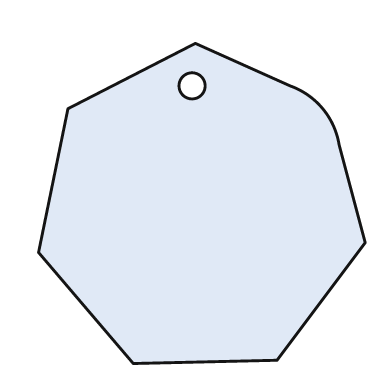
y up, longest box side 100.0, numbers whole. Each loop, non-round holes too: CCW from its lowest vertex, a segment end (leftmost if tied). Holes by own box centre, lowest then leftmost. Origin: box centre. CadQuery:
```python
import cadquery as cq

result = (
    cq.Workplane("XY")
    .moveTo(-21.0, -49.0)
    .lineTo(23.0, -48.0)
    .lineTo(50.0, -12.0)
    .lineTo(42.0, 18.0)
    .threePointArc((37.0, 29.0), (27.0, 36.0))
    .lineTo(-2.0, 49.0)
    .lineTo(-41.0, 29.0)
    .lineTo(-50.0, -15.0)
    .close()
    .moveTo(-3.0, 36.0)
    .circle(4.0)
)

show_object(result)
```